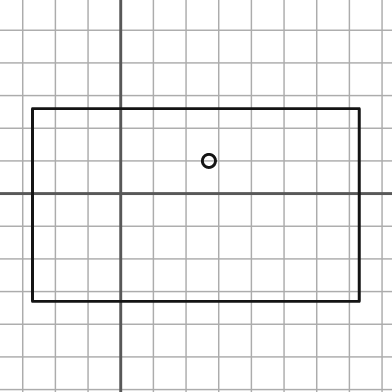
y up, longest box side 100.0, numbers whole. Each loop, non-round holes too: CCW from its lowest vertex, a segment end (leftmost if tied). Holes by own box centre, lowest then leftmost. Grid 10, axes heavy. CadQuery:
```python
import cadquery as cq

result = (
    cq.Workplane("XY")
    .moveTo(-27.0, -33.0)
    .lineTo(73.0, -33.0)
    .lineTo(73.0, 26.0)
    .lineTo(-27.0, 26.0)
    .close()
    .moveTo(27.0, 10.0)
    .circle(2.0)
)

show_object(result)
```